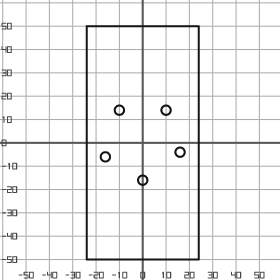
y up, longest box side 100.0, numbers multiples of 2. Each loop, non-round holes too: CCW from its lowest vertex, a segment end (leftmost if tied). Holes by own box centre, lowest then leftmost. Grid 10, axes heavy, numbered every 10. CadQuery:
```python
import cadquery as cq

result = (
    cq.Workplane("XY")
    .moveTo(-24.0, -50.0)
    .lineTo(24.0, -50.0)
    .lineTo(24.0, 50.0)
    .lineTo(-24.0, 50.0)
    .close()
    .moveTo(0.0, -16.0)
    .circle(2.0)
    .moveTo(-16.0, -6.0)
    .circle(2.0)
    .moveTo(16.0, -4.0)
    .circle(2.0)
    .moveTo(-10.0, 14.0)
    .circle(2.0)
    .moveTo(10.0, 14.0)
    .circle(2.0)
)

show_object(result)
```